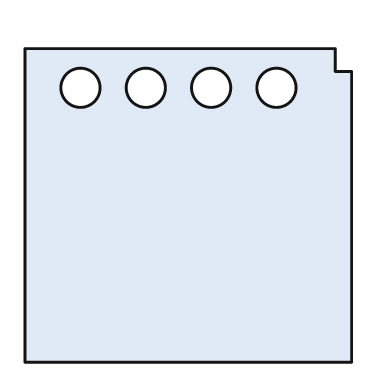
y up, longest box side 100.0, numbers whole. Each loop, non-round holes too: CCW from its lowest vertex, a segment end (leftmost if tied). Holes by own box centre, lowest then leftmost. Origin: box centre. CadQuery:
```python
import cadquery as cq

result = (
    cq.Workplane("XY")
    .moveTo(-50.0, -48.0)
    .lineTo(50.0, -48.0)
    .lineTo(50.0, 41.0)
    .lineTo(45.0, 41.0)
    .lineTo(45.0, 48.0)
    .lineTo(-50.0, 48.0)
    .close()
    .moveTo(-33.0, 36.0)
    .circle(6.0)
    .moveTo(-13.0, 36.0)
    .circle(6.0)
    .moveTo(7.0, 36.0)
    .circle(6.0)
    .moveTo(27.0, 36.0)
    .circle(6.0)
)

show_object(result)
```